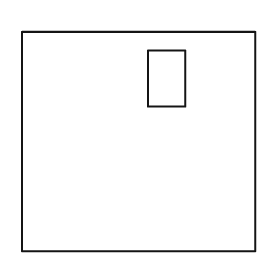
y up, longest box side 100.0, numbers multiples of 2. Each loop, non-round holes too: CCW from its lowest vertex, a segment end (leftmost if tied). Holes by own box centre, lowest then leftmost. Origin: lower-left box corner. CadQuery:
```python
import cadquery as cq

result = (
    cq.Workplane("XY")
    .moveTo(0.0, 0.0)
    .lineTo(100.0, 0.0)
    .lineTo(100.0, 94.0)
    .lineTo(0.0, 94.0)
    .close()
    .moveTo(54.0, 62.0)
    .lineTo(70.0, 62.0)
    .lineTo(70.0, 86.0)
    .lineTo(54.0, 86.0)
    .close()
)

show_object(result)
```